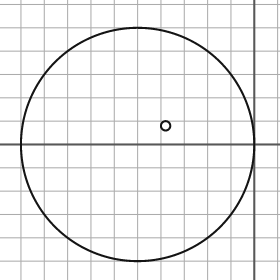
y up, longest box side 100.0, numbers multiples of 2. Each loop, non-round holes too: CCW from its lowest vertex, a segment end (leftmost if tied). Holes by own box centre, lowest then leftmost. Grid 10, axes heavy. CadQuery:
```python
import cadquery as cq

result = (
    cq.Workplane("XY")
    .moveTo(-50.0, 0.0)
    .circle(50.0)
    .moveTo(-38.0, 8.0)
    .circle(2.0)
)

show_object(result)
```